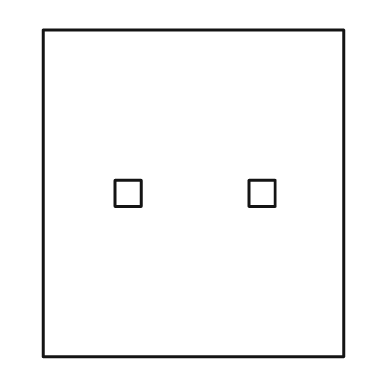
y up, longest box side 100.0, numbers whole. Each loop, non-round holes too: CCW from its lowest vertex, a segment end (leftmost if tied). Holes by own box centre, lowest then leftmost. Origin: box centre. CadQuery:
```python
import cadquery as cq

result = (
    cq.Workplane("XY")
    .moveTo(-46.0, -50.0)
    .lineTo(46.0, -50.0)
    .lineTo(46.0, 50.0)
    .lineTo(-46.0, 50.0)
    .close()
    .moveTo(-24.0, -4.0)
    .lineTo(-16.0, -4.0)
    .lineTo(-16.0, 4.0)
    .lineTo(-24.0, 4.0)
    .close()
    .moveTo(17.0, -4.0)
    .lineTo(25.0, -4.0)
    .lineTo(25.0, 4.0)
    .lineTo(17.0, 4.0)
    .close()
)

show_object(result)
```